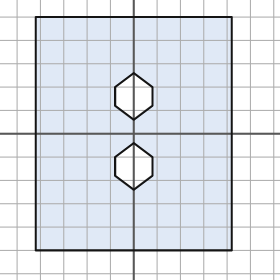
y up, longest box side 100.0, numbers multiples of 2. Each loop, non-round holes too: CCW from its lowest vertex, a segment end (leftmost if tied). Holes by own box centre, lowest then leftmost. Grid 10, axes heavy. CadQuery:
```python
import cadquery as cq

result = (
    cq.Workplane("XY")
    .moveTo(-42.0, -50.0)
    .lineTo(42.0, -50.0)
    .lineTo(42.0, 50.0)
    .lineTo(-42.0, 50.0)
    .close()
    .moveTo(0.0, -24.0)
    .lineTo(8.0, -18.0)
    .lineTo(8.0, -10.0)
    .lineTo(0.0, -4.0)
    .lineTo(-8.0, -10.0)
    .lineTo(-8.0, -18.0)
    .close()
    .moveTo(0.0, 6.0)
    .lineTo(8.0, 12.0)
    .lineTo(8.0, 20.0)
    .lineTo(0.0, 26.0)
    .lineTo(-8.0, 20.0)
    .lineTo(-8.0, 12.0)
    .close()
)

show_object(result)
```